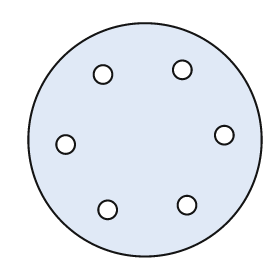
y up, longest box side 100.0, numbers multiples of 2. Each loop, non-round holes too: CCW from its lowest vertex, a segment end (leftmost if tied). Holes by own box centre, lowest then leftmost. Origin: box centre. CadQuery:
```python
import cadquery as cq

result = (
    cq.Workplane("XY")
    .moveTo(0.0, 0.0)
    .circle(50.0)
    .moveTo(-16.0, -30.0)
    .circle(4.0)
    .moveTo(18.0, -28.0)
    .circle(4.0)
    .moveTo(-34.0, -2.0)
    .circle(4.0)
    .moveTo(34.0, 2.0)
    .circle(4.0)
    .moveTo(-18.0, 28.0)
    .circle(4.0)
    .moveTo(16.0, 30.0)
    .circle(4.0)
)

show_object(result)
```